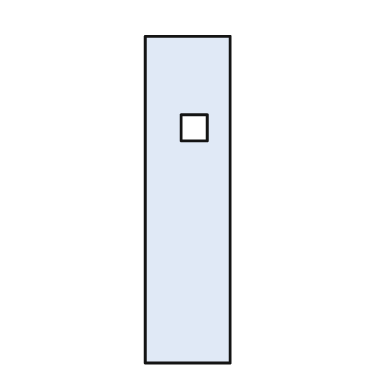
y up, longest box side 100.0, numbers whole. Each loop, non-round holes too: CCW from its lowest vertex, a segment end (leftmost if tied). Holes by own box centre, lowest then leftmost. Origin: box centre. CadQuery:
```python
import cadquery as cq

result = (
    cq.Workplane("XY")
    .moveTo(-13.0, -50.0)
    .lineTo(13.0, -50.0)
    .lineTo(13.0, 50.0)
    .lineTo(-13.0, 50.0)
    .close()
    .moveTo(-2.0, 18.0)
    .lineTo(6.0, 18.0)
    .lineTo(6.0, 26.0)
    .lineTo(-2.0, 26.0)
    .close()
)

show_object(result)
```